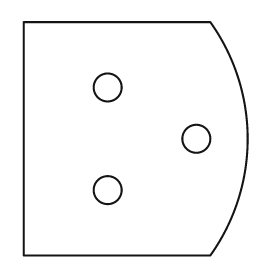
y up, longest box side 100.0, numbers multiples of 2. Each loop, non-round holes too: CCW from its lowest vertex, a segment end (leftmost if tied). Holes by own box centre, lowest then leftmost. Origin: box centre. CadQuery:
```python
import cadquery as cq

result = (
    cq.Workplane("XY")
    .moveTo(-48.0, -50.0)
    .lineTo(32.0, -50.0)
    .threePointArc((48.0, 0.0), (32.0, 50.0))
    .lineTo(-48.0, 50.0)
    .close()
    .moveTo(-12.0, -22.0)
    .circle(6.0)
    .moveTo(26.0, 0.0)
    .circle(6.0)
    .moveTo(-12.0, 22.0)
    .circle(6.0)
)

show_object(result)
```